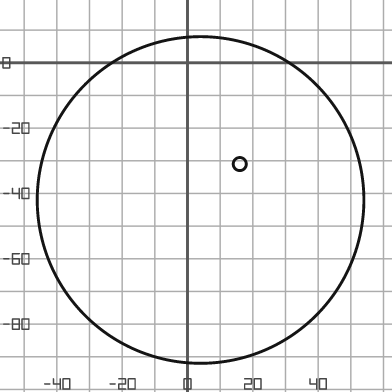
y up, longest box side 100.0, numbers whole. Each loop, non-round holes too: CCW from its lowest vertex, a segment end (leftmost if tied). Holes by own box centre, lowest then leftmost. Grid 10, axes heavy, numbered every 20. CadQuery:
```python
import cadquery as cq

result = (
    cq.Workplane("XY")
    .moveTo(4.0, -42.0)
    .circle(50.0)
    .moveTo(16.0, -31.0)
    .circle(2.0)
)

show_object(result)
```